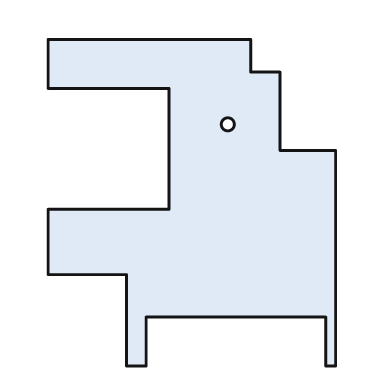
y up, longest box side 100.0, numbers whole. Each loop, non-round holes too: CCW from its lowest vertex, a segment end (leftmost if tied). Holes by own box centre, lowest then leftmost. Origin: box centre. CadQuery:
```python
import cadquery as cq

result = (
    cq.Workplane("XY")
    .moveTo(-20.0, -50.0)
    .lineTo(-14.0, -50.0)
    .lineTo(-14.0, -35.0)
    .lineTo(41.0, -35.0)
    .lineTo(41.0, -50.0)
    .lineTo(44.0, -50.0)
    .lineTo(44.0, 16.0)
    .lineTo(27.0, 16.0)
    .lineTo(27.0, 40.0)
    .lineTo(18.0, 40.0)
    .lineTo(18.0, 50.0)
    .lineTo(-44.0, 50.0)
    .lineTo(-44.0, 35.0)
    .lineTo(-7.0, 35.0)
    .lineTo(-7.0, -2.0)
    .lineTo(-44.0, -2.0)
    .lineTo(-44.0, -22.0)
    .lineTo(-20.0, -22.0)
    .close()
    .moveTo(11.0, 24.0)
    .circle(2.0)
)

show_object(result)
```